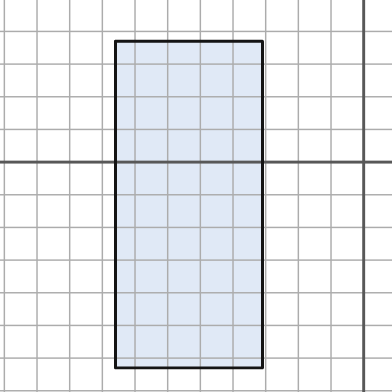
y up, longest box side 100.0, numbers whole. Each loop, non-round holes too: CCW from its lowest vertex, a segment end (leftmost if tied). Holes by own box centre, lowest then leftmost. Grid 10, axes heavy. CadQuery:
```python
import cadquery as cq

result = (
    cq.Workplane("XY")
    .moveTo(-76.0, -63.0)
    .lineTo(-31.0, -63.0)
    .lineTo(-31.0, 37.0)
    .lineTo(-76.0, 37.0)
    .close()
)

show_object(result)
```